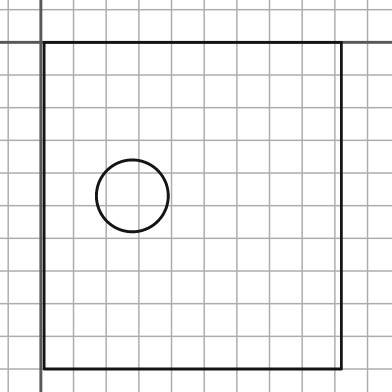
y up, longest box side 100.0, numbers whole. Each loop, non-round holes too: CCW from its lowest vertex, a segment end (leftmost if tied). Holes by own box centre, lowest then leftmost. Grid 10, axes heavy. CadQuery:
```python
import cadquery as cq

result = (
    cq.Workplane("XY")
    .moveTo(1.0, -100.0)
    .lineTo(92.0, -100.0)
    .lineTo(92.0, 0.0)
    .lineTo(1.0, 0.0)
    .close()
    .moveTo(28.0, -47.0)
    .circle(11.0)
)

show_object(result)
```